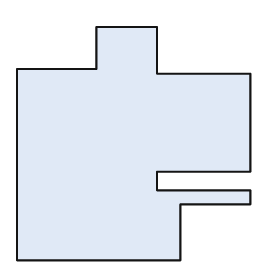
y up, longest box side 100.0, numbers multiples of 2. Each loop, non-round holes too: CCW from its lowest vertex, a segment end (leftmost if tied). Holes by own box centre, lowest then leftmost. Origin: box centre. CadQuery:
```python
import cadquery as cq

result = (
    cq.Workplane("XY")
    .moveTo(-50.0, -50.0)
    .lineTo(20.0, -50.0)
    .lineTo(20.0, -26.0)
    .lineTo(50.0, -26.0)
    .lineTo(50.0, -20.0)
    .lineTo(10.0, -20.0)
    .lineTo(10.0, -12.0)
    .lineTo(50.0, -12.0)
    .lineTo(50.0, 30.0)
    .lineTo(10.0, 30.0)
    .lineTo(10.0, 50.0)
    .lineTo(-16.0, 50.0)
    .lineTo(-16.0, 32.0)
    .lineTo(-50.0, 32.0)
    .close()
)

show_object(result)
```